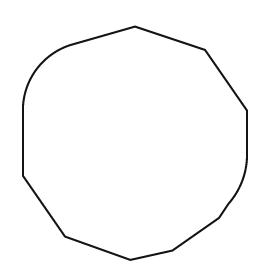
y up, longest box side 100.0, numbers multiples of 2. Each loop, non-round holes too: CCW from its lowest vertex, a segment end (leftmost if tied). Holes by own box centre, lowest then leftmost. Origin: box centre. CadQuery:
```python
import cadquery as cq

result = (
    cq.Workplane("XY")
    .moveTo(-2.0, -50.0)
    .lineTo(16.0, -46.0)
    .lineTo(36.0, -32.0)
    .lineTo(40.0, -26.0)
    .threePointArc((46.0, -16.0), (48.0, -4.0))
    .lineTo(48.0, 14.0)
    .lineTo(30.0, 40.0)
    .lineTo(0.0, 50.0)
    .lineTo(-28.0, 42.0)
    .threePointArc((-42.0, 32.0), (-48.0, 16.0))
    .lineTo(-48.0, -14.0)
    .lineTo(-30.0, -40.0)
    .close()
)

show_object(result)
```